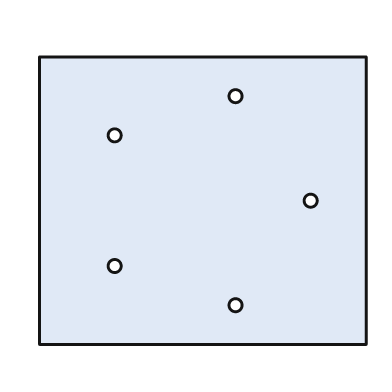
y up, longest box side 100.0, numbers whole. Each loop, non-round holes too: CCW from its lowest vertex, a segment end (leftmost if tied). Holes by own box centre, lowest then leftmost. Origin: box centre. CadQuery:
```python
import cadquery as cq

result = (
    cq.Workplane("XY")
    .moveTo(-50.0, -44.0)
    .lineTo(50.0, -44.0)
    .lineTo(50.0, 44.0)
    .lineTo(-50.0, 44.0)
    .close()
    .moveTo(10.0, -32.0)
    .circle(2.0)
    .moveTo(-27.0, -20.0)
    .circle(2.0)
    .moveTo(33.0, 0.0)
    .circle(2.0)
    .moveTo(-27.0, 20.0)
    .circle(2.0)
    .moveTo(10.0, 32.0)
    .circle(2.0)
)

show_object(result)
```